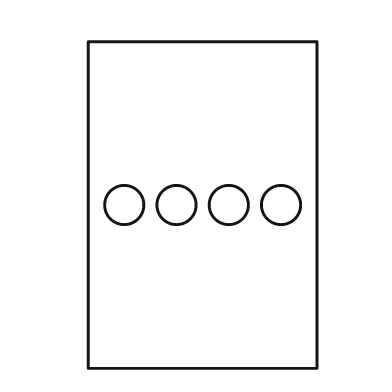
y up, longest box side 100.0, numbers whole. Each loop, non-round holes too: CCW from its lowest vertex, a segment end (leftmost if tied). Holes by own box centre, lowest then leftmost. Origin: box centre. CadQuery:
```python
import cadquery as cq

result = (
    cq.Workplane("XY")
    .moveTo(-35.0, -50.0)
    .lineTo(35.0, -50.0)
    .lineTo(35.0, 50.0)
    .lineTo(-35.0, 50.0)
    .close()
    .moveTo(-24.0, 0.0)
    .circle(6.0)
    .moveTo(-8.0, 0.0)
    .circle(6.0)
    .moveTo(8.0, 0.0)
    .circle(6.0)
    .moveTo(24.0, 0.0)
    .circle(6.0)
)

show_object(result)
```